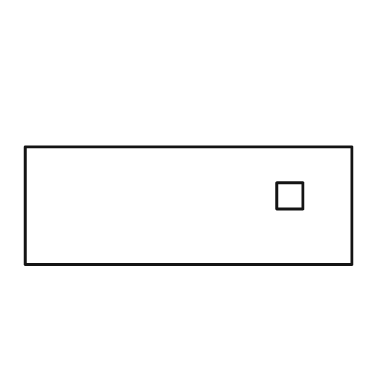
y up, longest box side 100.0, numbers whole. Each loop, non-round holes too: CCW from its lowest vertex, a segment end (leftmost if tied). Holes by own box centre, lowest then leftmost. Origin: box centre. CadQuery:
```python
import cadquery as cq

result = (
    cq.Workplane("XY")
    .moveTo(-50.0, -18.0)
    .lineTo(50.0, -18.0)
    .lineTo(50.0, 18.0)
    .lineTo(-50.0, 18.0)
    .close()
    .moveTo(27.0, -1.0)
    .lineTo(35.0, -1.0)
    .lineTo(35.0, 7.0)
    .lineTo(27.0, 7.0)
    .close()
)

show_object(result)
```